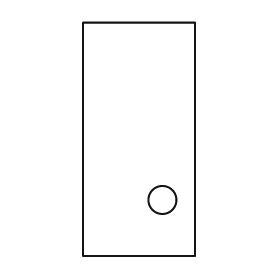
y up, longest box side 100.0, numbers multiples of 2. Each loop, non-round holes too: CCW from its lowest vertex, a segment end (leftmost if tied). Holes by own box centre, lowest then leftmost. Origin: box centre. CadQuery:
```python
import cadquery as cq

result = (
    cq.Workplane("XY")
    .moveTo(-24.0, -50.0)
    .lineTo(24.0, -50.0)
    .lineTo(24.0, 50.0)
    .lineTo(-24.0, 50.0)
    .close()
    .moveTo(10.0, -26.0)
    .circle(6.0)
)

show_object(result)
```